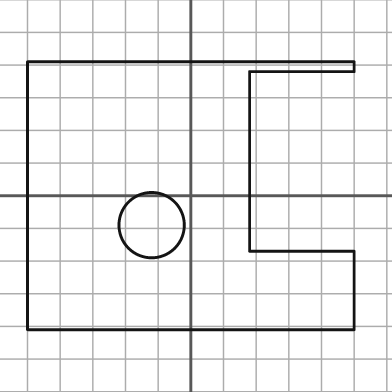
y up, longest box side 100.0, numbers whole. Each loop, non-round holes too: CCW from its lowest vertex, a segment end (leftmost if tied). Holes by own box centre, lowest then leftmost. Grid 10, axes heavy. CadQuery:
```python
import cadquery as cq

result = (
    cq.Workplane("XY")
    .moveTo(-50.0, -41.0)
    .lineTo(50.0, -41.0)
    .lineTo(50.0, -17.0)
    .lineTo(18.0, -17.0)
    .lineTo(18.0, 38.0)
    .lineTo(50.0, 38.0)
    .lineTo(50.0, 41.0)
    .lineTo(-50.0, 41.0)
    .close()
    .moveTo(-12.0, -9.0)
    .circle(10.0)
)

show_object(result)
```